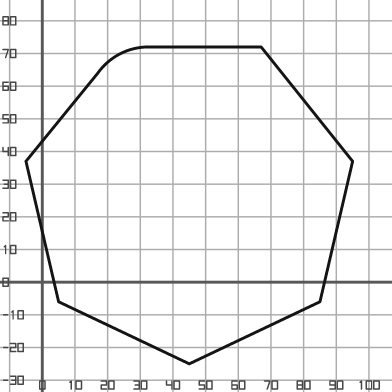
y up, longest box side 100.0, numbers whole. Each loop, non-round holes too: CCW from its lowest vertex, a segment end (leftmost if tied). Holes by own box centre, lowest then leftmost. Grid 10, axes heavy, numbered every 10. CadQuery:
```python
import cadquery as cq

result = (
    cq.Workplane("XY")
    .moveTo(45.0, -25.0)
    .lineTo(85.0, -6.0)
    .lineTo(95.0, 37.0)
    .lineTo(67.0, 72.0)
    .lineTo(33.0, 72.0)
    .threePointArc((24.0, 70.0), (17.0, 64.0))
    .lineTo(-5.0, 37.0)
    .lineTo(5.0, -6.0)
    .close()
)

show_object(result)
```